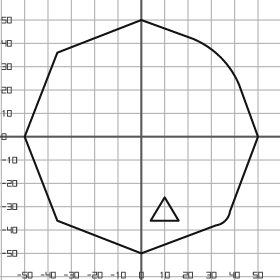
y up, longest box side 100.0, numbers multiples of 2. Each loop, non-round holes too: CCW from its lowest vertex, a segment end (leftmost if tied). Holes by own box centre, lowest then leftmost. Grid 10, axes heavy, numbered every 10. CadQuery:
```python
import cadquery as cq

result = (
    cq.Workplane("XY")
    .moveTo(0.0, -50.0)
    .lineTo(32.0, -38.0)
    .threePointArc((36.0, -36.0), (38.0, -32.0))
    .lineTo(50.0, 0.0)
    .lineTo(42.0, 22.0)
    .threePointArc((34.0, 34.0), (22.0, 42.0))
    .lineTo(0.0, 50.0)
    .lineTo(-36.0, 36.0)
    .lineTo(-50.0, 0.0)
    .lineTo(-36.0, -36.0)
    .close()
    .moveTo(4.0, -36.0)
    .lineTo(16.0, -36.0)
    .lineTo(10.0, -26.0)
    .close()
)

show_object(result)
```